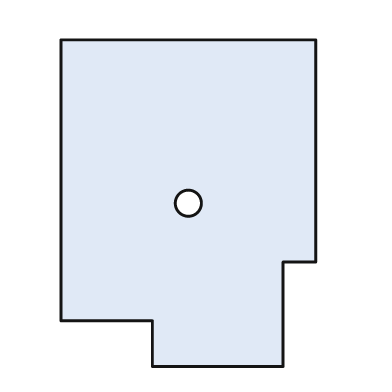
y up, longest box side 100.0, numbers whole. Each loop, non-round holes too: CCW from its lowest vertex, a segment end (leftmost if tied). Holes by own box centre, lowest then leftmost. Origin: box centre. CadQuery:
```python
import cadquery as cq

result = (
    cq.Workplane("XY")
    .moveTo(-11.0, -50.0)
    .lineTo(29.0, -50.0)
    .lineTo(29.0, -18.0)
    .lineTo(39.0, -18.0)
    .lineTo(39.0, 50.0)
    .lineTo(-39.0, 50.0)
    .lineTo(-39.0, -36.0)
    .lineTo(-11.0, -36.0)
    .close()
    .moveTo(0.0, 0.0)
    .circle(4.0)
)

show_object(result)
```